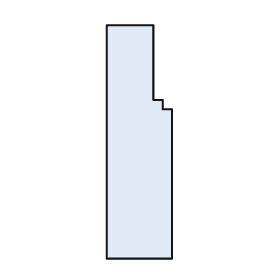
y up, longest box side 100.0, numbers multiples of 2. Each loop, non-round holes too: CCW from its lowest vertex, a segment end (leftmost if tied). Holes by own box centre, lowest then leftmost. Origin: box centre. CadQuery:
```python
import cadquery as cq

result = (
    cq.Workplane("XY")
    .moveTo(-14.0, -50.0)
    .lineTo(14.0, -50.0)
    .lineTo(14.0, 14.0)
    .lineTo(10.0, 14.0)
    .lineTo(10.0, 18.0)
    .lineTo(6.0, 18.0)
    .lineTo(6.0, 50.0)
    .lineTo(-14.0, 50.0)
    .close()
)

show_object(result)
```